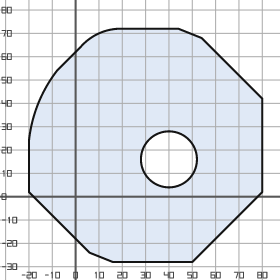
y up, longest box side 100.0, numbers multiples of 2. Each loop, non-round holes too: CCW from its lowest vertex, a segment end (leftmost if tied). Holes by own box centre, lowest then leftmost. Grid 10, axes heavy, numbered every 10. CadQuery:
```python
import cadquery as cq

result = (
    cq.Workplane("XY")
    .moveTo(16.0, -28.0)
    .lineTo(50.0, -28.0)
    .lineTo(80.0, 2.0)
    .lineTo(80.0, 42.0)
    .lineTo(54.0, 68.0)
    .lineTo(44.0, 72.0)
    .lineTo(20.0, 72.0)
    .threePointArc((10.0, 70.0), (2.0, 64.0))
    .lineTo(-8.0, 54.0)
    .threePointArc((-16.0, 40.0), (-20.0, 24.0))
    .lineTo(-20.0, 2.0)
    .lineTo(6.0, -24.0)
    .close()
    .moveTo(40.0, 16.0)
    .circle(12.0)
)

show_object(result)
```